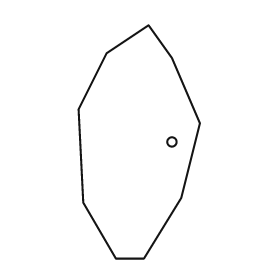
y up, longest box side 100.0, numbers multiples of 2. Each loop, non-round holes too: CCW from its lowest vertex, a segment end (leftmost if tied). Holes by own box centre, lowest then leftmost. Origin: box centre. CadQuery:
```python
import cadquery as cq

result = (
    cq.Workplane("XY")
    .moveTo(-10.0, -50.0)
    .lineTo(2.0, -50.0)
    .lineTo(18.0, -24.0)
    .lineTo(26.0, 8.0)
    .lineTo(14.0, 36.0)
    .lineTo(4.0, 50.0)
    .lineTo(-14.0, 38.0)
    .lineTo(-26.0, 14.0)
    .lineTo(-24.0, -26.0)
    .close()
    .moveTo(14.0, 0.0)
    .circle(2.0)
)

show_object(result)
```